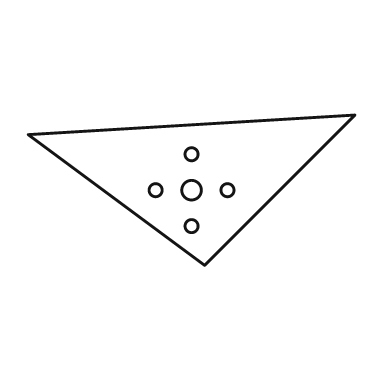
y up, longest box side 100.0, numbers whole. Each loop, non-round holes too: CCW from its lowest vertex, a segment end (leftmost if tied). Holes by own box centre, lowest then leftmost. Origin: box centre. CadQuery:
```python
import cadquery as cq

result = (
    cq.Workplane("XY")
    .moveTo(4.0, -23.0)
    .lineTo(50.0, 23.0)
    .lineTo(-50.0, 17.0)
    .close()
    .moveTo(0.0, -11.0)
    .circle(2.0)
    .moveTo(-11.0, 0.0)
    .circle(2.0)
    .moveTo(0.0, 0.0)
    .circle(3.0)
    .moveTo(11.0, 0.0)
    .circle(2.0)
    .moveTo(0.0, 11.0)
    .circle(2.0)
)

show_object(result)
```